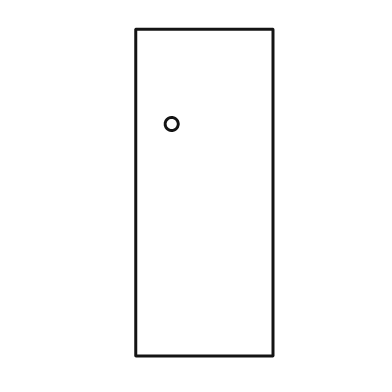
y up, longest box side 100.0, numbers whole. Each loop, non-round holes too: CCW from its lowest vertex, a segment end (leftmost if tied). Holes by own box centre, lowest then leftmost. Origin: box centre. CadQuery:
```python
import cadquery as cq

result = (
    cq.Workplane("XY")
    .moveTo(-21.0, -50.0)
    .lineTo(21.0, -50.0)
    .lineTo(21.0, 50.0)
    .lineTo(-21.0, 50.0)
    .close()
    .moveTo(-10.0, 21.0)
    .circle(2.0)
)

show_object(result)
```